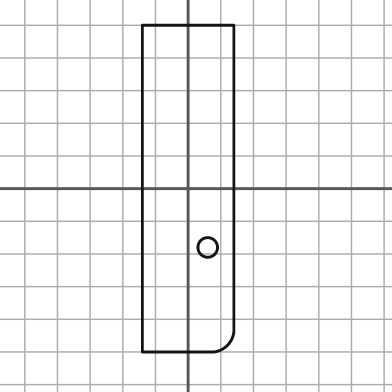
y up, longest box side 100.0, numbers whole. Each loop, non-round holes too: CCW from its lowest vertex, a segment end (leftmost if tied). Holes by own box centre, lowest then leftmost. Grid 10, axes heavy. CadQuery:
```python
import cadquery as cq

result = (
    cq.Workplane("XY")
    .moveTo(-14.0, -50.0)
    .lineTo(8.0, -50.0)
    .threePointArc((12.0, -48.0), (14.0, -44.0))
    .lineTo(14.0, 50.0)
    .lineTo(-14.0, 50.0)
    .close()
    .moveTo(6.0, -18.0)
    .circle(3.0)
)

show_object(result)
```